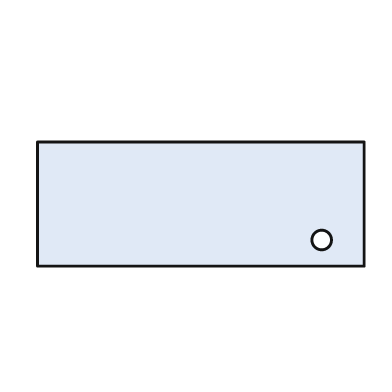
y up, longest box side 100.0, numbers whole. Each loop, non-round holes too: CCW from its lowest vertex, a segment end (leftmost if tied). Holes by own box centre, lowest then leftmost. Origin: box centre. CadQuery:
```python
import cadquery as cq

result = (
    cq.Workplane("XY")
    .moveTo(-50.0, -19.0)
    .lineTo(50.0, -19.0)
    .lineTo(50.0, 19.0)
    .lineTo(-50.0, 19.0)
    .close()
    .moveTo(37.0, -11.0)
    .circle(3.0)
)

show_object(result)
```